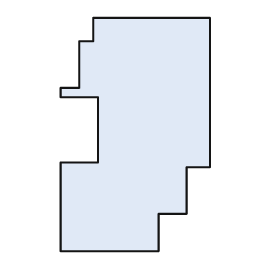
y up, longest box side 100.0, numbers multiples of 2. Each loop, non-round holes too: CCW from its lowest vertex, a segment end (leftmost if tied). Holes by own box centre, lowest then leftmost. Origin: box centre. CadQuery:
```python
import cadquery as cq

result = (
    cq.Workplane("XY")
    .moveTo(-32.0, -50.0)
    .lineTo(10.0, -50.0)
    .lineTo(10.0, -34.0)
    .lineTo(22.0, -34.0)
    .lineTo(22.0, -14.0)
    .lineTo(32.0, -14.0)
    .lineTo(32.0, 50.0)
    .lineTo(-18.0, 50.0)
    .lineTo(-18.0, 40.0)
    .lineTo(-24.0, 40.0)
    .lineTo(-24.0, 20.0)
    .lineTo(-32.0, 20.0)
    .lineTo(-32.0, 16.0)
    .lineTo(-16.0, 16.0)
    .lineTo(-16.0, -12.0)
    .lineTo(-32.0, -12.0)
    .close()
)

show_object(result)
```